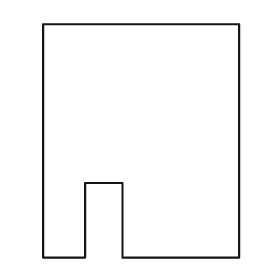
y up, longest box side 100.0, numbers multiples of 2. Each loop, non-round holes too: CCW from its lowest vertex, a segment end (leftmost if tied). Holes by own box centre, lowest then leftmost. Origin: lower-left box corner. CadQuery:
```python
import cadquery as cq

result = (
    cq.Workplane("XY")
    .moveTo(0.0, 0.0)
    .lineTo(18.0, 0.0)
    .lineTo(18.0, 32.0)
    .lineTo(34.0, 32.0)
    .lineTo(34.0, 0.0)
    .lineTo(84.0, 0.0)
    .lineTo(84.0, 100.0)
    .lineTo(0.0, 100.0)
    .close()
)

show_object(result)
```